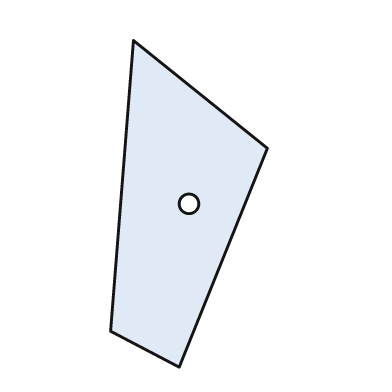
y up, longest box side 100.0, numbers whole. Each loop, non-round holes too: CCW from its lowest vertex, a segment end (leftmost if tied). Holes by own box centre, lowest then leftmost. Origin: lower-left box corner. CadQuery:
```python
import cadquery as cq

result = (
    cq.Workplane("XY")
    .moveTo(21.0, 0.0)
    .lineTo(48.0, 67.0)
    .lineTo(7.0, 100.0)
    .lineTo(0.0, 11.0)
    .close()
    .moveTo(24.0, 50.0)
    .circle(3.0)
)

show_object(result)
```